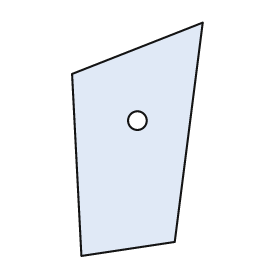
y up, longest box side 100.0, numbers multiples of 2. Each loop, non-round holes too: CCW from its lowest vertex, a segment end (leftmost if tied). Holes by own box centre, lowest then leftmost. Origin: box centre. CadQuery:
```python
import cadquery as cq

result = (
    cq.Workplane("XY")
    .moveTo(-24.0, -50.0)
    .lineTo(16.0, -44.0)
    .lineTo(28.0, 50.0)
    .lineTo(-28.0, 28.0)
    .close()
    .moveTo(0.0, 8.0)
    .circle(4.0)
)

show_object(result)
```